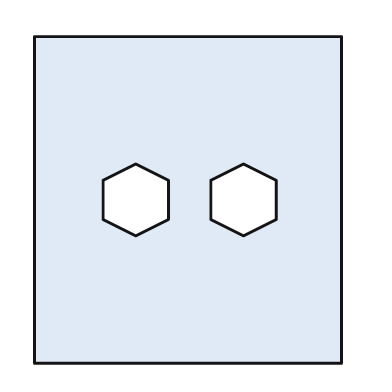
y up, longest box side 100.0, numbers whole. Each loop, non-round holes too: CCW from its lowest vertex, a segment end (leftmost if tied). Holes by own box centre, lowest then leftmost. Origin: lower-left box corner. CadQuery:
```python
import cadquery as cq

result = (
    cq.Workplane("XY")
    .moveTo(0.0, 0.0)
    .lineTo(94.0, 0.0)
    .lineTo(94.0, 100.0)
    .lineTo(0.0, 100.0)
    .close()
    .moveTo(31.0, 39.0)
    .lineTo(41.0, 44.0)
    .lineTo(41.0, 56.0)
    .lineTo(31.0, 61.0)
    .lineTo(21.0, 56.0)
    .lineTo(21.0, 44.0)
    .close()
    .moveTo(64.0, 39.0)
    .lineTo(74.0, 44.0)
    .lineTo(74.0, 56.0)
    .lineTo(64.0, 61.0)
    .lineTo(54.0, 56.0)
    .lineTo(54.0, 44.0)
    .close()
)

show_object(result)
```